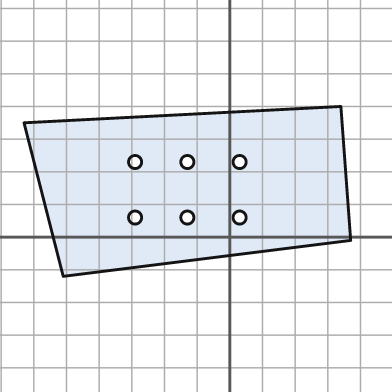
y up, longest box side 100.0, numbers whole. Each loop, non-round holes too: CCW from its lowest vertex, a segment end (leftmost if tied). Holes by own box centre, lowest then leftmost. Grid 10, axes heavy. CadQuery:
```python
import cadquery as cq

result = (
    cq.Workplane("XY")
    .moveTo(-51.0, -12.0)
    .lineTo(37.0, -1.0)
    .lineTo(34.0, 40.0)
    .lineTo(-63.0, 35.0)
    .close()
    .moveTo(-29.0, 6.0)
    .circle(2.0)
    .moveTo(-13.0, 6.0)
    .circle(2.0)
    .moveTo(3.0, 6.0)
    .circle(2.0)
    .moveTo(-29.0, 23.0)
    .circle(2.0)
    .moveTo(-13.0, 23.0)
    .circle(2.0)
    .moveTo(3.0, 23.0)
    .circle(2.0)
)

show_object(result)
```